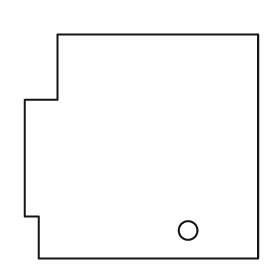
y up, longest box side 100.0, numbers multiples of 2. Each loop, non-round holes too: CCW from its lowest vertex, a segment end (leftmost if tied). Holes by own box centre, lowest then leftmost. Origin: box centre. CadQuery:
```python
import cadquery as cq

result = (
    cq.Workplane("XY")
    .moveTo(-44.0, -48.0)
    .lineTo(50.0, -48.0)
    .lineTo(50.0, 48.0)
    .lineTo(-36.0, 48.0)
    .lineTo(-36.0, 20.0)
    .lineTo(-50.0, 20.0)
    .lineTo(-50.0, -30.0)
    .lineTo(-44.0, -30.0)
    .close()
    .moveTo(20.0, -36.0)
    .circle(4.0)
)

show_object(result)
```